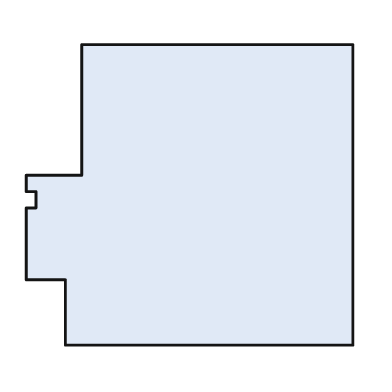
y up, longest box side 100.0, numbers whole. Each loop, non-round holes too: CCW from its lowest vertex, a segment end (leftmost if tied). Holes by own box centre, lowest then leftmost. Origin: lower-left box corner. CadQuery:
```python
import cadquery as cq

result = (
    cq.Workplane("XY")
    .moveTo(12.0, 0.0)
    .lineTo(100.0, 0.0)
    .lineTo(100.0, 92.0)
    .lineTo(17.0, 92.0)
    .lineTo(17.0, 52.0)
    .lineTo(0.0, 52.0)
    .lineTo(0.0, 47.0)
    .lineTo(3.0, 47.0)
    .lineTo(3.0, 42.0)
    .lineTo(0.0, 42.0)
    .lineTo(0.0, 20.0)
    .lineTo(12.0, 20.0)
    .close()
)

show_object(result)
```